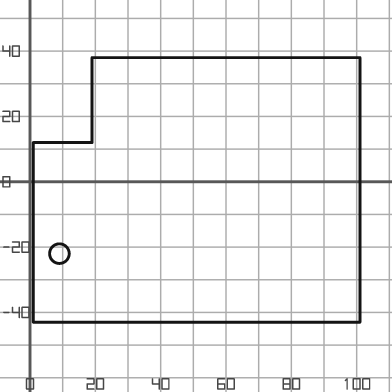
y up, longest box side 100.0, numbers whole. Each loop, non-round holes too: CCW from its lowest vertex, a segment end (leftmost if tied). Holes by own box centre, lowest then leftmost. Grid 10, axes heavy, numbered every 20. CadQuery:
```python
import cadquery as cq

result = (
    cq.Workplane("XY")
    .moveTo(1.0, -43.0)
    .lineTo(101.0, -43.0)
    .lineTo(101.0, 38.0)
    .lineTo(19.0, 38.0)
    .lineTo(19.0, 12.0)
    .lineTo(1.0, 12.0)
    .close()
    .moveTo(9.0, -22.0)
    .circle(3.0)
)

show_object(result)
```